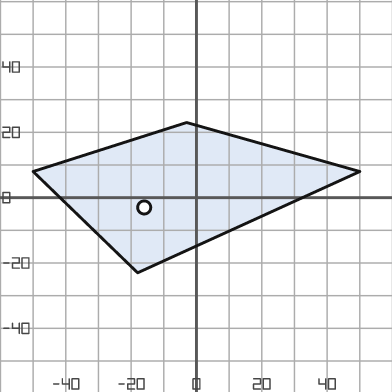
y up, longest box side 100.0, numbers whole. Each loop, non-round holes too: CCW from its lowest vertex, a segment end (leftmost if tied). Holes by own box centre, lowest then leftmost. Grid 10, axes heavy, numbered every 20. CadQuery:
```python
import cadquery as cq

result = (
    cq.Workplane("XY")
    .moveTo(-18.0, -23.0)
    .lineTo(50.0, 8.0)
    .lineTo(-3.0, 23.0)
    .lineTo(-50.0, 8.0)
    .close()
    .moveTo(-16.0, -3.0)
    .circle(2.0)
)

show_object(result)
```